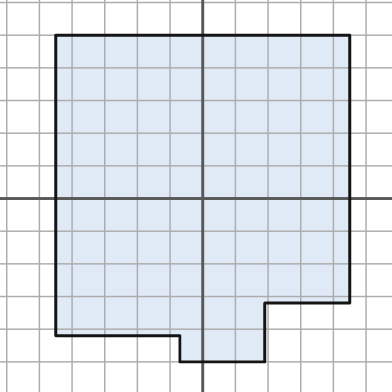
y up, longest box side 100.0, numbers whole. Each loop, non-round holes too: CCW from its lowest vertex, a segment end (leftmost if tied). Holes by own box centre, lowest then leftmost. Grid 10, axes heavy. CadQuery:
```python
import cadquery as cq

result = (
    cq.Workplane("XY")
    .moveTo(-7.0, -50.0)
    .lineTo(19.0, -50.0)
    .lineTo(19.0, -32.0)
    .lineTo(45.0, -32.0)
    .lineTo(45.0, 50.0)
    .lineTo(-45.0, 50.0)
    .lineTo(-45.0, -42.0)
    .lineTo(-7.0, -42.0)
    .close()
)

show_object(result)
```